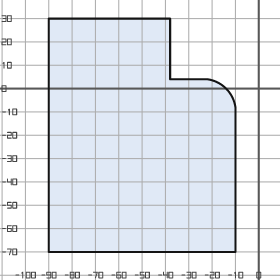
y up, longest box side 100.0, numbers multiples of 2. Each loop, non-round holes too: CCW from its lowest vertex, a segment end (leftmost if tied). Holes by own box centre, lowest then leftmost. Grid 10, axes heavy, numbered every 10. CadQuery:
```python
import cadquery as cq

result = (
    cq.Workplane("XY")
    .moveTo(-90.0, -70.0)
    .lineTo(-10.0, -70.0)
    .lineTo(-10.0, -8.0)
    .threePointArc((-14.0, 0.0), (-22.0, 4.0))
    .lineTo(-38.0, 4.0)
    .lineTo(-38.0, 30.0)
    .lineTo(-90.0, 30.0)
    .close()
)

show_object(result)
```